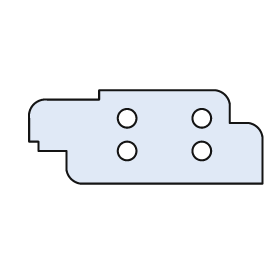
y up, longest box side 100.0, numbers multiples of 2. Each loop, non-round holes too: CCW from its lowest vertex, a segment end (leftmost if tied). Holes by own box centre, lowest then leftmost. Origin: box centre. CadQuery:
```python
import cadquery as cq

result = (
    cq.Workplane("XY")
    .moveTo(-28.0, -20.0)
    .lineTo(50.0, -20.0)
    .lineTo(50.0, 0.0)
    .threePointArc((48.0, 4.0), (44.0, 6.0))
    .lineTo(36.0, 6.0)
    .lineTo(36.0, 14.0)
    .threePointArc((34.0, 18.0), (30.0, 20.0))
    .lineTo(-20.0, 20.0)
    .lineTo(-20.0, 16.0)
    .lineTo(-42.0, 16.0)
    .threePointArc((-48.0, 14.0), (-50.0, 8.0))
    .lineTo(-50.0, -2.0)
    .lineTo(-46.0, -2.0)
    .lineTo(-46.0, -6.0)
    .lineTo(-34.0, -6.0)
    .lineTo(-34.0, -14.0)
    .threePointArc((-32.0, -18.0), (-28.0, -20.0))
    .close()
    .moveTo(-8.0, -6.0)
    .circle(4.0)
    .moveTo(24.0, -6.0)
    .circle(4.0)
    .moveTo(-8.0, 8.0)
    .circle(4.0)
    .moveTo(24.0, 8.0)
    .circle(4.0)
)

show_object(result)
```